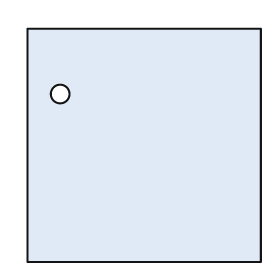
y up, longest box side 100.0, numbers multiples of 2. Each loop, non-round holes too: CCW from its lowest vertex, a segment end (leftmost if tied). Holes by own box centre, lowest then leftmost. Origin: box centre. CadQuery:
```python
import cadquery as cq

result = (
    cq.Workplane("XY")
    .moveTo(-50.0, -50.0)
    .lineTo(50.0, -50.0)
    .lineTo(50.0, 50.0)
    .lineTo(-50.0, 50.0)
    .close()
    .moveTo(-36.0, 22.0)
    .circle(4.0)
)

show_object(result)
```